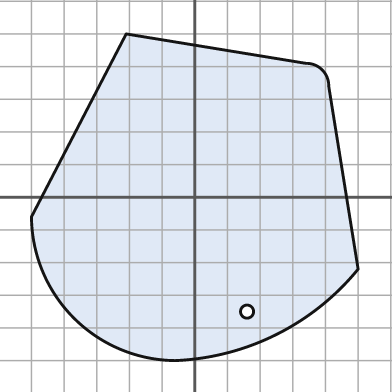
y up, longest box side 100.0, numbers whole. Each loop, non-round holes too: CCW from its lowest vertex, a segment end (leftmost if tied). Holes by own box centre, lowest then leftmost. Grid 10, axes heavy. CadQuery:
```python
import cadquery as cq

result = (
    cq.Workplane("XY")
    .moveTo(-6.0, -50.0)
    .threePointArc((25.0, -42.0), (50.0, -22.0))
    .lineTo(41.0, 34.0)
    .threePointArc((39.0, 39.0), (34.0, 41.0))
    .lineTo(-21.0, 50.0)
    .lineTo(-50.0, -6.0)
    .threePointArc((-37.0, -37.0), (-6.0, -50.0))
    .close()
    .moveTo(16.0, -35.0)
    .circle(2.0)
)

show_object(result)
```